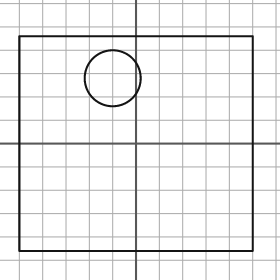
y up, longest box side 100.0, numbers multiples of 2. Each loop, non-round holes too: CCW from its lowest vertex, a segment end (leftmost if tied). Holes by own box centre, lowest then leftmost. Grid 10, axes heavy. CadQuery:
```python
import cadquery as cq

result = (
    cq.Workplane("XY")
    .moveTo(-50.0, -46.0)
    .lineTo(50.0, -46.0)
    .lineTo(50.0, 46.0)
    .lineTo(-50.0, 46.0)
    .close()
    .moveTo(-10.0, 28.0)
    .circle(12.0)
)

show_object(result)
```